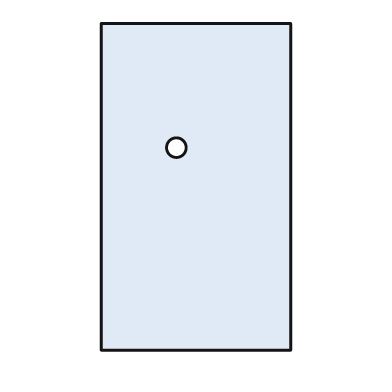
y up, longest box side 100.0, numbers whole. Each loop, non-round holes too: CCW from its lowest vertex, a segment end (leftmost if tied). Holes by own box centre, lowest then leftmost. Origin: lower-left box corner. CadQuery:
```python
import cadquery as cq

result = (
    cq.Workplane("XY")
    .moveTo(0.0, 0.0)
    .lineTo(58.0, 0.0)
    .lineTo(58.0, 100.0)
    .lineTo(0.0, 100.0)
    .close()
    .moveTo(23.0, 62.0)
    .circle(3.0)
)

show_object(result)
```